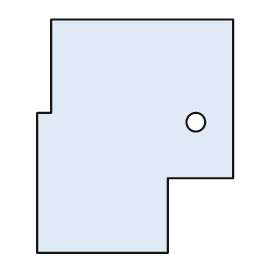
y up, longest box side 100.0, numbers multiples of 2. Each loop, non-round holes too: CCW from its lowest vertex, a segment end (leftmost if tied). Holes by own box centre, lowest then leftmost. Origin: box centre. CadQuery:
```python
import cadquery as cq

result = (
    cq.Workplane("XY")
    .moveTo(-42.0, -50.0)
    .lineTo(14.0, -50.0)
    .lineTo(14.0, -18.0)
    .lineTo(42.0, -18.0)
    .lineTo(42.0, 50.0)
    .lineTo(-36.0, 50.0)
    .lineTo(-36.0, 10.0)
    .lineTo(-42.0, 10.0)
    .close()
    .moveTo(26.0, 6.0)
    .circle(4.0)
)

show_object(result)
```